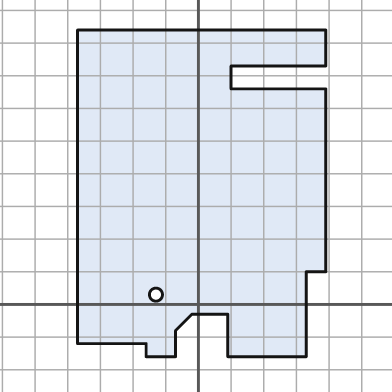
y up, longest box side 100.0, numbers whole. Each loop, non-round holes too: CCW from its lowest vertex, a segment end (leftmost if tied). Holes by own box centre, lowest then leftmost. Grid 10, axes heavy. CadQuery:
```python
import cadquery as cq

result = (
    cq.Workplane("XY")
    .moveTo(-16.0, -16.0)
    .lineTo(-7.0, -16.0)
    .lineTo(-7.0, -8.0)
    .lineTo(-2.0, -3.0)
    .lineTo(9.0, -3.0)
    .lineTo(9.0, -16.0)
    .lineTo(33.0, -16.0)
    .lineTo(33.0, 10.0)
    .lineTo(39.0, 10.0)
    .lineTo(39.0, 66.0)
    .lineTo(10.0, 66.0)
    .lineTo(10.0, 73.0)
    .lineTo(39.0, 73.0)
    .lineTo(39.0, 84.0)
    .lineTo(-37.0, 84.0)
    .lineTo(-37.0, -12.0)
    .lineTo(-16.0, -12.0)
    .close()
    .moveTo(-13.0, 3.0)
    .circle(2.0)
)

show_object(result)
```